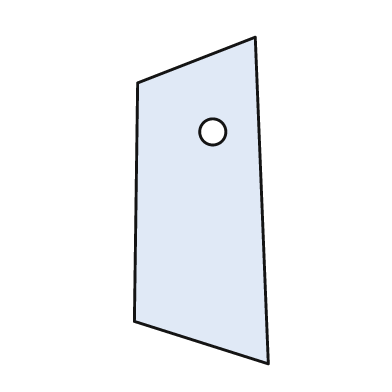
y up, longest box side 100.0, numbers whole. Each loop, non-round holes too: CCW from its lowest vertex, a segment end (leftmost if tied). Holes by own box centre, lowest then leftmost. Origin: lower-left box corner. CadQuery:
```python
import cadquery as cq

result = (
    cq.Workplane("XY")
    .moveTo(41.0, 0.0)
    .lineTo(37.0, 100.0)
    .lineTo(1.0, 86.0)
    .lineTo(0.0, 13.0)
    .close()
    .moveTo(24.0, 71.0)
    .circle(4.0)
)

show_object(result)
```